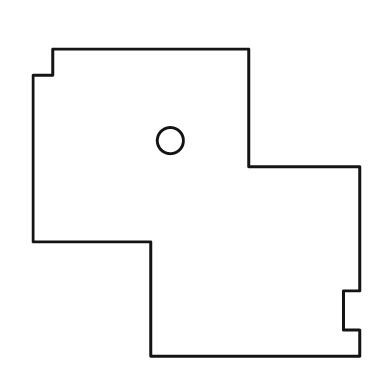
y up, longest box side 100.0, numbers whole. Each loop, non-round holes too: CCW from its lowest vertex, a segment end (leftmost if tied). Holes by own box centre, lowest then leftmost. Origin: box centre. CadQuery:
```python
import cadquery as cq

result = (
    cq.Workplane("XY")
    .moveTo(-14.0, -47.0)
    .lineTo(50.0, -47.0)
    .lineTo(50.0, -39.0)
    .lineTo(45.0, -39.0)
    .lineTo(45.0, -27.0)
    .lineTo(50.0, -27.0)
    .lineTo(50.0, 11.0)
    .lineTo(16.0, 11.0)
    .lineTo(16.0, 47.0)
    .lineTo(-44.0, 47.0)
    .lineTo(-44.0, 39.0)
    .lineTo(-50.0, 39.0)
    .lineTo(-50.0, -12.0)
    .lineTo(-14.0, -12.0)
    .close()
    .moveTo(-8.0, 19.0)
    .circle(4.0)
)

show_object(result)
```